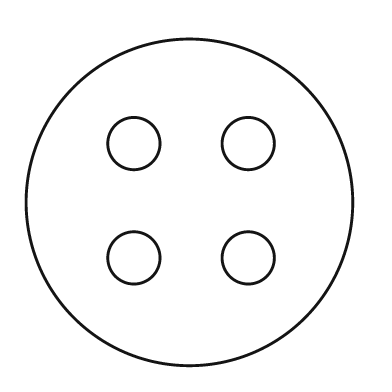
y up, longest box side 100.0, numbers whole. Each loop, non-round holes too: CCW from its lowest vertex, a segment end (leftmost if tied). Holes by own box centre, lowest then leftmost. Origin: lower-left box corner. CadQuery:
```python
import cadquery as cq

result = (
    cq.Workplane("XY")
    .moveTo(50.0, 50.0)
    .circle(50.0)
    .moveTo(33.0, 33.0)
    .circle(8.0)
    .moveTo(68.0, 33.0)
    .circle(8.0)
    .moveTo(33.0, 68.0)
    .circle(8.0)
    .moveTo(68.0, 68.0)
    .circle(8.0)
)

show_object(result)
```